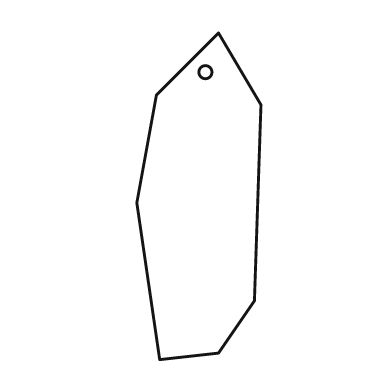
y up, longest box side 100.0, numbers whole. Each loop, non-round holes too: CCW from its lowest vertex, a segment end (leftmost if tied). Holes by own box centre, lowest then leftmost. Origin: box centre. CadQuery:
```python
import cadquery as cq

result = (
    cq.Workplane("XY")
    .moveTo(-12.0, -50.0)
    .lineTo(6.0, -48.0)
    .lineTo(17.0, -32.0)
    .lineTo(19.0, 28.0)
    .lineTo(6.0, 50.0)
    .lineTo(-13.0, 31.0)
    .lineTo(-19.0, -2.0)
    .close()
    .moveTo(2.0, 38.0)
    .circle(2.0)
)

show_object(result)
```